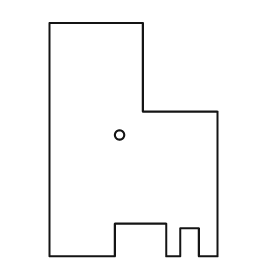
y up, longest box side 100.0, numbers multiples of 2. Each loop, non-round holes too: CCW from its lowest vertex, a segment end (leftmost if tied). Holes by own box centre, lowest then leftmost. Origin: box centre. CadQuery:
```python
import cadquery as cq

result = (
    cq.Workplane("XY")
    .moveTo(-36.0, -50.0)
    .lineTo(-8.0, -50.0)
    .lineTo(-8.0, -36.0)
    .lineTo(14.0, -36.0)
    .lineTo(14.0, -50.0)
    .lineTo(20.0, -50.0)
    .lineTo(20.0, -38.0)
    .lineTo(28.0, -38.0)
    .lineTo(28.0, -50.0)
    .lineTo(36.0, -50.0)
    .lineTo(36.0, 12.0)
    .lineTo(4.0, 12.0)
    .lineTo(4.0, 50.0)
    .lineTo(-36.0, 50.0)
    .close()
    .moveTo(-6.0, 2.0)
    .circle(2.0)
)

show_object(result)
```